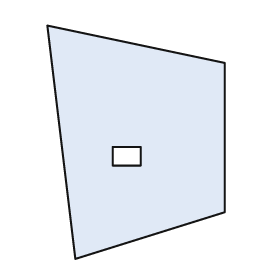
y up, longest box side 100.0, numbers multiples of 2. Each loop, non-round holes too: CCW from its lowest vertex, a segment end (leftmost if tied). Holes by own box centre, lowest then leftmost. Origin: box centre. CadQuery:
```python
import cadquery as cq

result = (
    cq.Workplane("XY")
    .moveTo(-26.0, -50.0)
    .lineTo(38.0, -30.0)
    .lineTo(38.0, 34.0)
    .lineTo(-38.0, 50.0)
    .close()
    .moveTo(-10.0, -10.0)
    .lineTo(2.0, -10.0)
    .lineTo(2.0, -2.0)
    .lineTo(-10.0, -2.0)
    .close()
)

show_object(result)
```